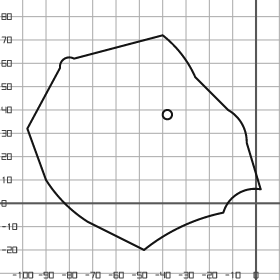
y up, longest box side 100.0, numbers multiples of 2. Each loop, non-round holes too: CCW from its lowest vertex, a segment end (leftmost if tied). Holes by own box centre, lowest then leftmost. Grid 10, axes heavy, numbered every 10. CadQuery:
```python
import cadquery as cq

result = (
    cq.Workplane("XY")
    .moveTo(-48.0, -20.0)
    .threePointArc((-32.0, -10.0), (-14.0, -4.0))
    .threePointArc((-8.0, 4.0), (2.0, 6.0))
    .lineTo(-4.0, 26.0)
    .threePointArc((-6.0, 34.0), (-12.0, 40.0))
    .lineTo(-26.0, 54.0)
    .threePointArc((-32.0, 64.0), (-40.0, 72.0))
    .lineTo(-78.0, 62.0)
    .threePointArc((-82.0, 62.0), (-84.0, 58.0))
    .lineTo(-98.0, 32.0)
    .lineTo(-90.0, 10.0)
    .threePointArc((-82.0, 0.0), (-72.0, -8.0))
    .close()
    .moveTo(-38.0, 38.0)
    .circle(2.0)
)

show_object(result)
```